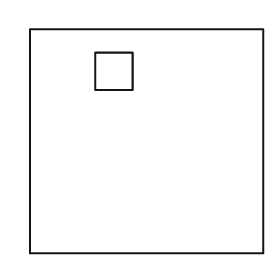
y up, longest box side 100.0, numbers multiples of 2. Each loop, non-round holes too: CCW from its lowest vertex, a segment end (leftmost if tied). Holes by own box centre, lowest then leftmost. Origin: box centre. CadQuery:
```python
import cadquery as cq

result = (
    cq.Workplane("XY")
    .moveTo(-50.0, -48.0)
    .lineTo(50.0, -48.0)
    .lineTo(50.0, 48.0)
    .lineTo(-50.0, 48.0)
    .close()
    .moveTo(-22.0, 22.0)
    .lineTo(-6.0, 22.0)
    .lineTo(-6.0, 38.0)
    .lineTo(-22.0, 38.0)
    .close()
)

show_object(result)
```